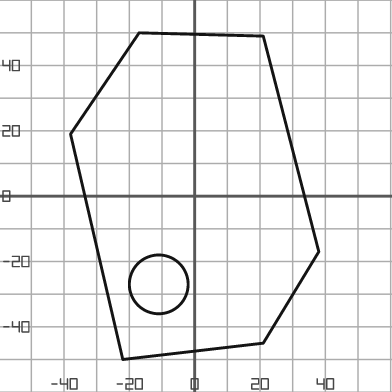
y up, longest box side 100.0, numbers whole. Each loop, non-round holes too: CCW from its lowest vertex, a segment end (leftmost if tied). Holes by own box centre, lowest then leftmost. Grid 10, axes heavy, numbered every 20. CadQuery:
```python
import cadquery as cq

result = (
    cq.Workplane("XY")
    .moveTo(-22.0, -50.0)
    .lineTo(21.0, -45.0)
    .lineTo(38.0, -17.0)
    .lineTo(21.0, 49.0)
    .lineTo(-17.0, 50.0)
    .lineTo(-38.0, 19.0)
    .close()
    .moveTo(-11.0, -27.0)
    .circle(9.0)
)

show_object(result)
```